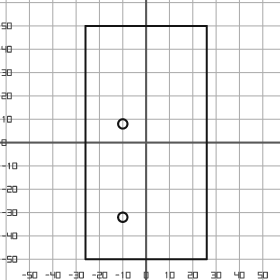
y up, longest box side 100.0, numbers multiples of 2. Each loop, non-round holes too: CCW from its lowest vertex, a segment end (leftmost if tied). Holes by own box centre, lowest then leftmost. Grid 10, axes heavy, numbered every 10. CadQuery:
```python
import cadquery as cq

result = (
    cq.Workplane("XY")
    .moveTo(-26.0, -50.0)
    .lineTo(26.0, -50.0)
    .lineTo(26.0, 50.0)
    .lineTo(-26.0, 50.0)
    .close()
    .moveTo(-10.0, -32.0)
    .circle(2.0)
    .moveTo(-10.0, 8.0)
    .circle(2.0)
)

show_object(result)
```